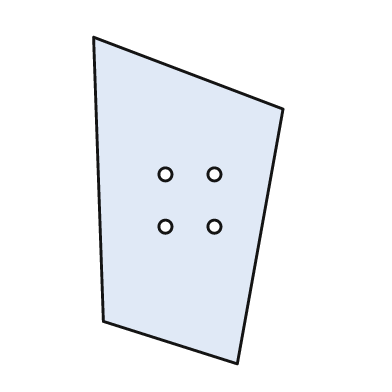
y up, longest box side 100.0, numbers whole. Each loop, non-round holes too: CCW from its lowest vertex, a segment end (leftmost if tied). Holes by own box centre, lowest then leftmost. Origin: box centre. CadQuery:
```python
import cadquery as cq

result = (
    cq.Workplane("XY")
    .moveTo(15.0, -50.0)
    .lineTo(29.0, 28.0)
    .lineTo(-29.0, 50.0)
    .lineTo(-26.0, -37.0)
    .close()
    .moveTo(-7.0, -8.0)
    .circle(2.0)
    .moveTo(8.0, -8.0)
    .circle(2.0)
    .moveTo(-7.0, 8.0)
    .circle(2.0)
    .moveTo(8.0, 8.0)
    .circle(2.0)
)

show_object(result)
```